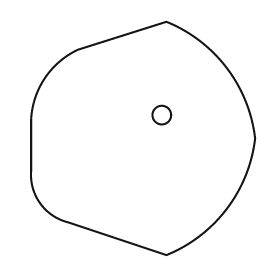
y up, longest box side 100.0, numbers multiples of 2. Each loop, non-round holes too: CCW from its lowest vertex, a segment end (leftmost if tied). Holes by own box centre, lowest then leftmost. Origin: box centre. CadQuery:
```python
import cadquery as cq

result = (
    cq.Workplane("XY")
    .moveTo(10.0, -50.0)
    .threePointArc((36.0, -30.0), (48.0, 0.0))
    .threePointArc((36.0, 30.0), (10.0, 50.0))
    .lineTo(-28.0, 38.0)
    .threePointArc((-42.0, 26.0), (-48.0, 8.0))
    .lineTo(-48.0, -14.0)
    .threePointArc((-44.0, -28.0), (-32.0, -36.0))
    .close()
    .moveTo(8.0, 10.0)
    .circle(4.0)
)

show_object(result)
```